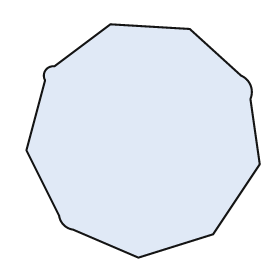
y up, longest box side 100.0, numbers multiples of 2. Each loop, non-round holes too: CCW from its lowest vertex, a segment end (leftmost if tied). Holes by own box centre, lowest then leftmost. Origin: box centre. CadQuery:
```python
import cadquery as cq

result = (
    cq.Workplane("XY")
    .moveTo(-2.0, -50.0)
    .lineTo(30.0, -40.0)
    .lineTo(50.0, -10.0)
    .lineTo(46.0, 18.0)
    .threePointArc((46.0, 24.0), (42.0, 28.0))
    .lineTo(20.0, 48.0)
    .lineTo(-14.0, 50.0)
    .lineTo(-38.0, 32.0)
    .threePointArc((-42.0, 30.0), (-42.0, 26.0))
    .lineTo(-50.0, -4.0)
    .lineTo(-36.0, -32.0)
    .threePointArc((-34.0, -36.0), (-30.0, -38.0))
    .close()
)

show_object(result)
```